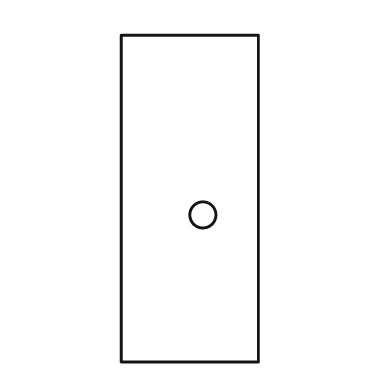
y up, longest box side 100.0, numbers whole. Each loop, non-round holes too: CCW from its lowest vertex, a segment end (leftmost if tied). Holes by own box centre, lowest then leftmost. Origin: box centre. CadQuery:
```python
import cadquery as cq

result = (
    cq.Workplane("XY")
    .moveTo(-21.0, -50.0)
    .lineTo(21.0, -50.0)
    .lineTo(21.0, 50.0)
    .lineTo(-21.0, 50.0)
    .close()
    .moveTo(4.0, -5.0)
    .circle(4.0)
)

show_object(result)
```